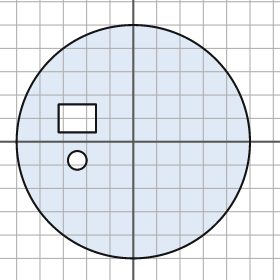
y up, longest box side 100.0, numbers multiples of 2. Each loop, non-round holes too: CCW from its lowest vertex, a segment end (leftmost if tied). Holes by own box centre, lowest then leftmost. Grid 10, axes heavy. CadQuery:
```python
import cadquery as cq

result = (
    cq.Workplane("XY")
    .moveTo(0.0, 0.0)
    .circle(50.0)
    .moveTo(-24.0, -8.0)
    .circle(4.0)
    .moveTo(-32.0, 4.0)
    .lineTo(-16.0, 4.0)
    .lineTo(-16.0, 16.0)
    .lineTo(-32.0, 16.0)
    .close()
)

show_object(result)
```